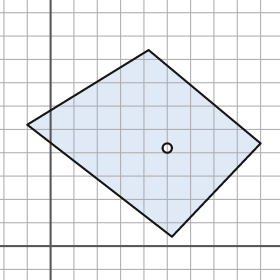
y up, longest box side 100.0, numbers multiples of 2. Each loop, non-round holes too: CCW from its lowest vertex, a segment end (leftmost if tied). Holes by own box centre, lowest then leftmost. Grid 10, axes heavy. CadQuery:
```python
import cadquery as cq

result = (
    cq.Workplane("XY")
    .moveTo(52.0, 4.0)
    .lineTo(90.0, 44.0)
    .lineTo(42.0, 84.0)
    .lineTo(-10.0, 52.0)
    .close()
    .moveTo(50.0, 42.0)
    .circle(2.0)
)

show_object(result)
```